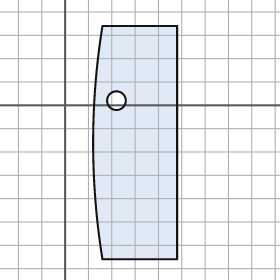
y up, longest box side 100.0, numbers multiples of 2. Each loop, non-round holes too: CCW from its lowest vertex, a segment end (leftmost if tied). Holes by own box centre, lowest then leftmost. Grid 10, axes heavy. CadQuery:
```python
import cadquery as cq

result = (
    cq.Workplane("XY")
    .moveTo(16.0, -66.0)
    .lineTo(48.0, -66.0)
    .lineTo(48.0, 34.0)
    .lineTo(16.0, 34.0)
    .threePointArc((12.0, -16.0), (16.0, -66.0))
    .close()
    .moveTo(22.0, 2.0)
    .circle(4.0)
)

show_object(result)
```